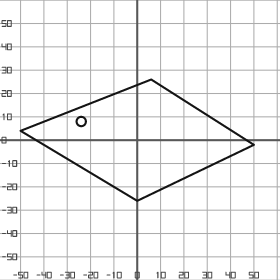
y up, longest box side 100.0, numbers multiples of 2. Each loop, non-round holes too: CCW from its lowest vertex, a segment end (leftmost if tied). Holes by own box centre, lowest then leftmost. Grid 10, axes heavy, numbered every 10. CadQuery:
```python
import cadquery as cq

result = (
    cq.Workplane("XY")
    .moveTo(0.0, -26.0)
    .lineTo(50.0, -2.0)
    .lineTo(6.0, 26.0)
    .lineTo(-50.0, 4.0)
    .close()
    .moveTo(-24.0, 8.0)
    .circle(2.0)
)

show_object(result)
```